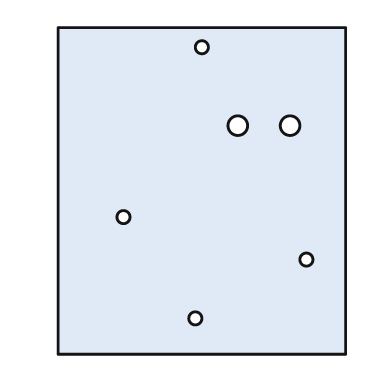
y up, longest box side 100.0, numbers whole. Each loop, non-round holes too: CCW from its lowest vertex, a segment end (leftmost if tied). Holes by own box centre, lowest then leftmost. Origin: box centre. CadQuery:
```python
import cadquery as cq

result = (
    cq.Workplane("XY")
    .moveTo(-44.0, -50.0)
    .lineTo(44.0, -50.0)
    .lineTo(44.0, 50.0)
    .lineTo(-44.0, 50.0)
    .close()
    .moveTo(-2.0, -39.0)
    .circle(2.0)
    .moveTo(32.0, -21.0)
    .circle(2.0)
    .moveTo(-24.0, -8.0)
    .circle(2.0)
    .moveTo(11.0, 20.0)
    .circle(3.0)
    .moveTo(27.0, 20.0)
    .circle(3.0)
    .moveTo(0.0, 44.0)
    .circle(2.0)
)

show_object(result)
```